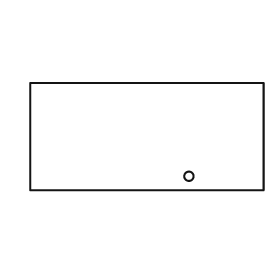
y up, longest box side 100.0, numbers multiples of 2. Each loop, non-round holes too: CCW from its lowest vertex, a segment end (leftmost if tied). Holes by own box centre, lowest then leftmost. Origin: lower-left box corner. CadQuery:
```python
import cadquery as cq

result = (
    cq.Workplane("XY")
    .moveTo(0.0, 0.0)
    .lineTo(100.0, 0.0)
    .lineTo(100.0, 46.0)
    .lineTo(0.0, 46.0)
    .close()
    .moveTo(68.0, 6.0)
    .circle(2.0)
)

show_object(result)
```